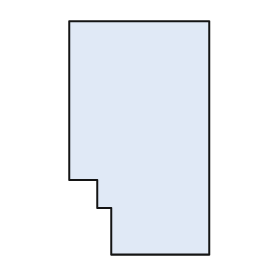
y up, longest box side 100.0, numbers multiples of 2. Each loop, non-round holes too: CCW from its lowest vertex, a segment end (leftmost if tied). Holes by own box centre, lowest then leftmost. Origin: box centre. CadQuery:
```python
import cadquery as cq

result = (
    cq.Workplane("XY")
    .moveTo(-12.0, -50.0)
    .lineTo(30.0, -50.0)
    .lineTo(30.0, 50.0)
    .lineTo(-30.0, 50.0)
    .lineTo(-30.0, -18.0)
    .lineTo(-18.0, -18.0)
    .lineTo(-18.0, -30.0)
    .lineTo(-12.0, -30.0)
    .close()
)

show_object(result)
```